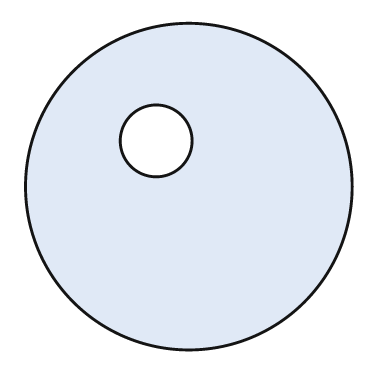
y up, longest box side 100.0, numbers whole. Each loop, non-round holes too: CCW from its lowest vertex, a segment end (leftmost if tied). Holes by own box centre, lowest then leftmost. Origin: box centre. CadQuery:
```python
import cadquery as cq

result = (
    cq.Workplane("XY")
    .moveTo(0.0, 0.0)
    .circle(50.0)
    .moveTo(-10.0, 14.0)
    .circle(11.0)
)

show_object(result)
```